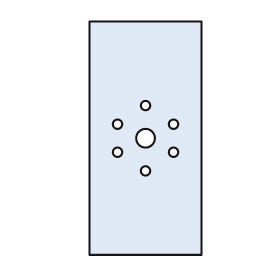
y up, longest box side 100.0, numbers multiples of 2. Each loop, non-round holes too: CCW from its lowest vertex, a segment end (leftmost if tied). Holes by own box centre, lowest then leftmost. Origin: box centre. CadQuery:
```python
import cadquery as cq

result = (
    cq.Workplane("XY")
    .moveTo(-24.0, -50.0)
    .lineTo(24.0, -50.0)
    .lineTo(24.0, 50.0)
    .lineTo(-24.0, 50.0)
    .close()
    .moveTo(0.0, -14.0)
    .circle(2.0)
    .moveTo(-12.0, -6.0)
    .circle(2.0)
    .moveTo(12.0, -6.0)
    .circle(2.0)
    .moveTo(0.0, 0.0)
    .circle(4.0)
    .moveTo(-12.0, 6.0)
    .circle(2.0)
    .moveTo(12.0, 6.0)
    .circle(2.0)
    .moveTo(0.0, 14.0)
    .circle(2.0)
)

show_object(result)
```